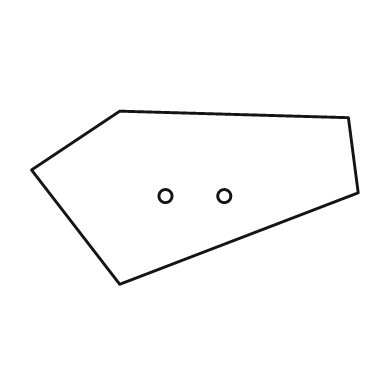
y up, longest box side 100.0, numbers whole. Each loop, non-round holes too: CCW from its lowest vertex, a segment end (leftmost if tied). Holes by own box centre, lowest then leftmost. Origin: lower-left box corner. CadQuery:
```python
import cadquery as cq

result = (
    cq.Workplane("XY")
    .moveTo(27.0, 0.0)
    .lineTo(100.0, 28.0)
    .lineTo(97.0, 51.0)
    .lineTo(27.0, 53.0)
    .lineTo(0.0, 35.0)
    .close()
    .moveTo(41.0, 27.0)
    .circle(2.0)
    .moveTo(59.0, 27.0)
    .circle(2.0)
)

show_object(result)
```